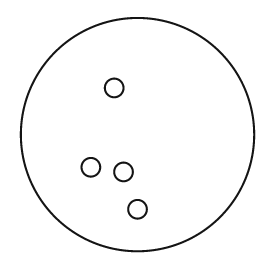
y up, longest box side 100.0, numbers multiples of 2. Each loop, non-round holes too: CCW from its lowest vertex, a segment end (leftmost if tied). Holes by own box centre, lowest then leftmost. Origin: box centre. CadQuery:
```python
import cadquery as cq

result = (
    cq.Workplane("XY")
    .moveTo(0.0, 0.0)
    .circle(50.0)
    .moveTo(0.0, -32.0)
    .circle(4.0)
    .moveTo(-6.0, -16.0)
    .circle(4.0)
    .moveTo(-20.0, -14.0)
    .circle(4.0)
    .moveTo(-10.0, 20.0)
    .circle(4.0)
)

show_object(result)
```